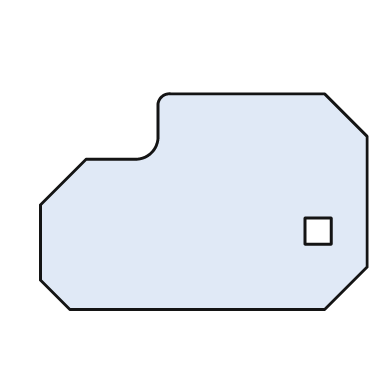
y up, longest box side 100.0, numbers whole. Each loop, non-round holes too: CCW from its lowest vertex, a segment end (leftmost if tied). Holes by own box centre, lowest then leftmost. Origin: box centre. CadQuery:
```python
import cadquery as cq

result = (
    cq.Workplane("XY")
    .moveTo(-41.0, -33.0)
    .lineTo(37.0, -33.0)
    .lineTo(50.0, -20.0)
    .lineTo(50.0, 20.0)
    .lineTo(37.0, 33.0)
    .lineTo(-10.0, 33.0)
    .threePointArc((-13.0, 32.0), (-14.0, 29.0))
    .lineTo(-14.0, 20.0)
    .threePointArc((-16.0, 15.0), (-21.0, 13.0))
    .lineTo(-36.0, 13.0)
    .lineTo(-50.0, -1.0)
    .lineTo(-50.0, -24.0)
    .close()
    .moveTo(31.0, -13.0)
    .lineTo(39.0, -13.0)
    .lineTo(39.0, -5.0)
    .lineTo(31.0, -5.0)
    .close()
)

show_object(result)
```